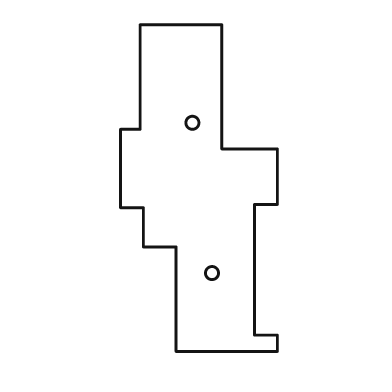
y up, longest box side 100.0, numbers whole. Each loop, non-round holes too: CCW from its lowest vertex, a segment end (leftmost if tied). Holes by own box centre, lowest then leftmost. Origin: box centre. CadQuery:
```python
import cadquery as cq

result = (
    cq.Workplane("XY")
    .moveTo(-7.0, -50.0)
    .lineTo(24.0, -50.0)
    .lineTo(24.0, -45.0)
    .lineTo(17.0, -45.0)
    .lineTo(17.0, -5.0)
    .lineTo(24.0, -5.0)
    .lineTo(24.0, 12.0)
    .lineTo(7.0, 12.0)
    .lineTo(7.0, 50.0)
    .lineTo(-18.0, 50.0)
    .lineTo(-18.0, 18.0)
    .lineTo(-24.0, 18.0)
    .lineTo(-24.0, -6.0)
    .lineTo(-17.0, -6.0)
    .lineTo(-17.0, -18.0)
    .lineTo(-7.0, -18.0)
    .close()
    .moveTo(4.0, -26.0)
    .circle(2.0)
    .moveTo(-2.0, 20.0)
    .circle(2.0)
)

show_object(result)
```